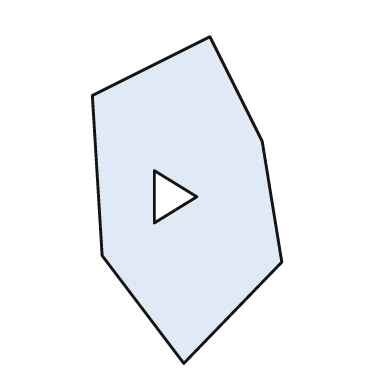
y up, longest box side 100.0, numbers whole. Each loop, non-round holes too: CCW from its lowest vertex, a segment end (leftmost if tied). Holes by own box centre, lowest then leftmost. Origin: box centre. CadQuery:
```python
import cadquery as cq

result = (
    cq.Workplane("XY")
    .moveTo(-1.0, -50.0)
    .lineTo(29.0, -19.0)
    .lineTo(23.0, 18.0)
    .lineTo(7.0, 50.0)
    .lineTo(-29.0, 32.0)
    .lineTo(-26.0, -17.0)
    .close()
    .moveTo(-10.0, -7.0)
    .lineTo(3.0, 1.0)
    .lineTo(-10.0, 9.0)
    .close()
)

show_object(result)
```